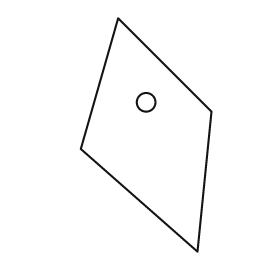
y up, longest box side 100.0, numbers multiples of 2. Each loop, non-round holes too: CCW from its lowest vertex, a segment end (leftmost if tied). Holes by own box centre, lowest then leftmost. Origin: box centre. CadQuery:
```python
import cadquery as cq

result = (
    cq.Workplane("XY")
    .moveTo(22.0, -50.0)
    .lineTo(28.0, 10.0)
    .lineTo(-12.0, 50.0)
    .lineTo(-28.0, -6.0)
    .close()
    .moveTo(0.0, 14.0)
    .circle(4.0)
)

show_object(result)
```